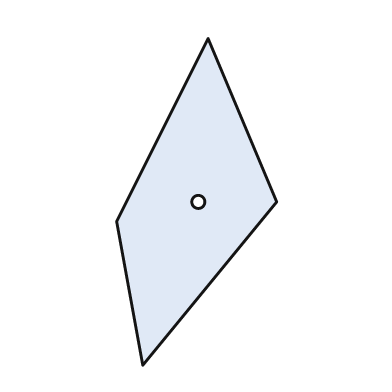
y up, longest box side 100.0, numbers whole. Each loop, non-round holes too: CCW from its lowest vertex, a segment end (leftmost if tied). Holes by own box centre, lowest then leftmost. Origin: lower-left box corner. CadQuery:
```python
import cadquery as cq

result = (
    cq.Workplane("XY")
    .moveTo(8.0, 0.0)
    .lineTo(49.0, 50.0)
    .lineTo(28.0, 100.0)
    .lineTo(0.0, 44.0)
    .close()
    .moveTo(25.0, 50.0)
    .circle(2.0)
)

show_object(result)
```